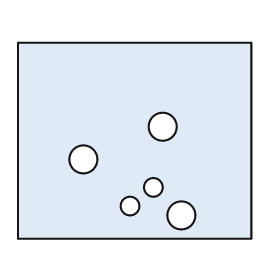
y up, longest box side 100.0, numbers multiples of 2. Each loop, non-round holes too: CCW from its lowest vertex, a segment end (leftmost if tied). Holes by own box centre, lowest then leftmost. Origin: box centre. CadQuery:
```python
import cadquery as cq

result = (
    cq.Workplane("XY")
    .moveTo(-50.0, -42.0)
    .lineTo(50.0, -42.0)
    .lineTo(50.0, 42.0)
    .lineTo(-50.0, 42.0)
    .close()
    .moveTo(20.0, -32.0)
    .circle(6.0)
    .moveTo(-2.0, -28.0)
    .circle(4.0)
    .moveTo(8.0, -20.0)
    .circle(4.0)
    .moveTo(-22.0, -8.0)
    .circle(6.0)
    .moveTo(12.0, 6.0)
    .circle(6.0)
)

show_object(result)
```